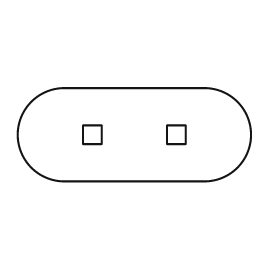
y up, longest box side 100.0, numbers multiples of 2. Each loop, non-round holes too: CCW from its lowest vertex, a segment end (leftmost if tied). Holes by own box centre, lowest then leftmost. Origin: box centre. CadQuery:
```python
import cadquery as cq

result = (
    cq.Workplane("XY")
    .moveTo(-30.0, -20.0)
    .lineTo(30.0, -20.0)
    .threePointArc((50.0, 0.0), (30.0, 20.0))
    .lineTo(-30.0, 20.0)
    .threePointArc((-50.0, 0.0), (-30.0, -20.0))
    .close()
    .moveTo(-22.0, -4.0)
    .lineTo(-14.0, -4.0)
    .lineTo(-14.0, 4.0)
    .lineTo(-22.0, 4.0)
    .close()
    .moveTo(14.0, -4.0)
    .lineTo(22.0, -4.0)
    .lineTo(22.0, 4.0)
    .lineTo(14.0, 4.0)
    .close()
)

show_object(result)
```